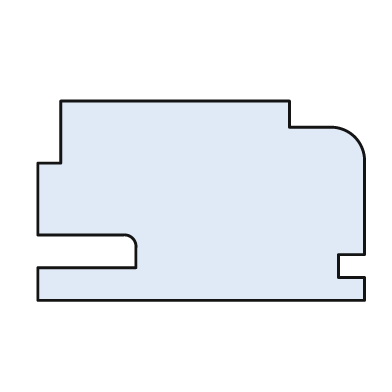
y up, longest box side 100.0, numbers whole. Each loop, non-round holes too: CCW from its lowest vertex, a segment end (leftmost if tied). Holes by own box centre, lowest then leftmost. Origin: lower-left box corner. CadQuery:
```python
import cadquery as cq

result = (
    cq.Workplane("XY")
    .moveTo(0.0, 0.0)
    .lineTo(100.0, 0.0)
    .lineTo(100.0, 7.0)
    .lineTo(92.0, 7.0)
    .lineTo(92.0, 14.0)
    .lineTo(100.0, 14.0)
    .lineTo(100.0, 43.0)
    .threePointArc((97.0, 50.0), (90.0, 53.0))
    .lineTo(77.0, 53.0)
    .lineTo(77.0, 61.0)
    .lineTo(7.0, 61.0)
    .lineTo(7.0, 42.0)
    .lineTo(0.0, 42.0)
    .lineTo(0.0, 20.0)
    .lineTo(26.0, 20.0)
    .threePointArc((29.0, 19.0), (30.0, 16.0))
    .lineTo(30.0, 10.0)
    .lineTo(0.0, 10.0)
    .close()
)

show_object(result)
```